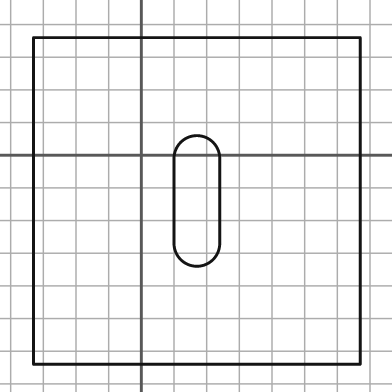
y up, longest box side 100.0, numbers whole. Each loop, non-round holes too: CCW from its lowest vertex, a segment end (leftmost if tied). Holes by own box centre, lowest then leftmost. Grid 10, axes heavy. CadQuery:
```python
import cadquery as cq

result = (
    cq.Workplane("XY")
    .moveTo(-33.0, -64.0)
    .lineTo(67.0, -64.0)
    .lineTo(67.0, 36.0)
    .lineTo(-33.0, 36.0)
    .close()
    .moveTo(10.0, -27.0)
    .threePointArc((17.0, -34.0), (24.0, -27.0))
    .lineTo(24.0, -1.0)
    .threePointArc((17.0, 6.0), (10.0, -1.0))
    .close()
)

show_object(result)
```